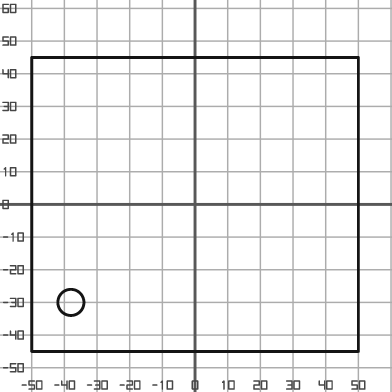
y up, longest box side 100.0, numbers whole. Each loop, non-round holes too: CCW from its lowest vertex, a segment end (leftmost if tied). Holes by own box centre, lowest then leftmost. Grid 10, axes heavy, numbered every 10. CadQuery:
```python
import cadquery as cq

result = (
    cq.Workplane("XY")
    .moveTo(-50.0, -45.0)
    .lineTo(50.0, -45.0)
    .lineTo(50.0, 45.0)
    .lineTo(-50.0, 45.0)
    .close()
    .moveTo(-38.0, -30.0)
    .circle(4.0)
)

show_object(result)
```